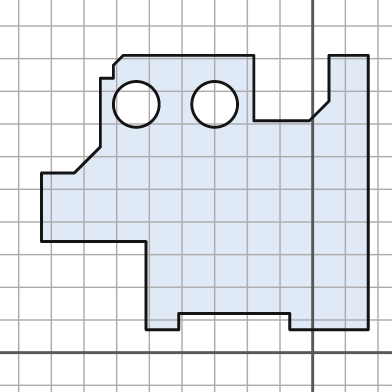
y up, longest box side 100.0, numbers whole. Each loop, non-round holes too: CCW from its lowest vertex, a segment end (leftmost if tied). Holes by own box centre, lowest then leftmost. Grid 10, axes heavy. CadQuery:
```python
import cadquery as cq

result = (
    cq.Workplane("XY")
    .moveTo(-51.0, 7.0)
    .lineTo(-41.0, 7.0)
    .lineTo(-41.0, 12.0)
    .lineTo(-7.0, 12.0)
    .lineTo(-7.0, 7.0)
    .lineTo(17.0, 7.0)
    .lineTo(17.0, 91.0)
    .lineTo(5.0, 91.0)
    .lineTo(5.0, 77.0)
    .lineTo(-1.0, 71.0)
    .lineTo(-18.0, 71.0)
    .lineTo(-18.0, 91.0)
    .lineTo(-58.0, 91.0)
    .lineTo(-61.0, 88.0)
    .lineTo(-61.0, 84.0)
    .lineTo(-65.0, 84.0)
    .lineTo(-65.0, 63.0)
    .lineTo(-73.0, 55.0)
    .lineTo(-83.0, 55.0)
    .lineTo(-83.0, 34.0)
    .lineTo(-51.0, 34.0)
    .close()
    .moveTo(-54.0, 76.0)
    .circle(7.0)
    .moveTo(-30.0, 76.0)
    .circle(7.0)
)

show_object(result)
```